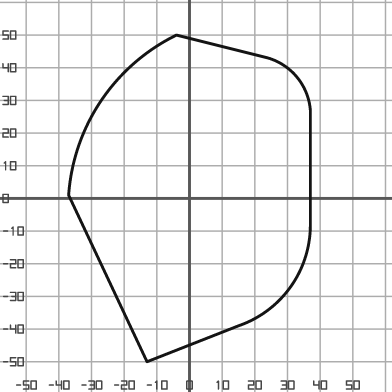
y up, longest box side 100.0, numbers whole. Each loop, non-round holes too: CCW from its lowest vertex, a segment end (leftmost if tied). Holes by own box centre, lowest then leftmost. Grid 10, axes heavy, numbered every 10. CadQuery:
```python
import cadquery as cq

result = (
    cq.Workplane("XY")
    .moveTo(-13.0, -50.0)
    .lineTo(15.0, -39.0)
    .threePointArc((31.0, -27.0), (37.0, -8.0))
    .lineTo(37.0, 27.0)
    .threePointArc((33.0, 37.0), (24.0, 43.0))
    .lineTo(-4.0, 50.0)
    .threePointArc((-27.0, 30.0), (-37.0, 1.0))
    .close()
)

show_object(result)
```